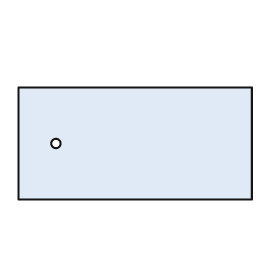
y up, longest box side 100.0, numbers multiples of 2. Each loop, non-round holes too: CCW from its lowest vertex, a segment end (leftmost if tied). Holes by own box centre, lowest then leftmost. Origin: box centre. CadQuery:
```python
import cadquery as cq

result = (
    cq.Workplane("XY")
    .moveTo(-50.0, -24.0)
    .lineTo(50.0, -24.0)
    .lineTo(50.0, 24.0)
    .lineTo(-50.0, 24.0)
    .close()
    .moveTo(-34.0, 0.0)
    .circle(2.0)
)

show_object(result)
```